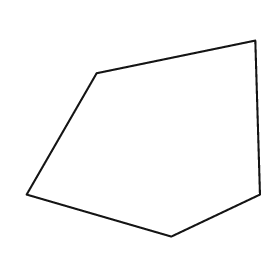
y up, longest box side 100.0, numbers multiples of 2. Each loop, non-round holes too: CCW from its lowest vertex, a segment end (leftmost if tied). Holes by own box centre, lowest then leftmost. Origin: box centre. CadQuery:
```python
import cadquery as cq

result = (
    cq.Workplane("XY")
    .moveTo(12.0, -42.0)
    .lineTo(50.0, -24.0)
    .lineTo(48.0, 42.0)
    .lineTo(-20.0, 28.0)
    .lineTo(-50.0, -24.0)
    .close()
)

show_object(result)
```